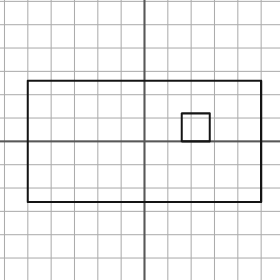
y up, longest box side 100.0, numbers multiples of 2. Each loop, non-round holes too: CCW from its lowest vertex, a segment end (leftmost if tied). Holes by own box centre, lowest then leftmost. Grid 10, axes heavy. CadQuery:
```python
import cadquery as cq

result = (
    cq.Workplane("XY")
    .moveTo(-50.0, -26.0)
    .lineTo(50.0, -26.0)
    .lineTo(50.0, 26.0)
    .lineTo(-50.0, 26.0)
    .close()
    .moveTo(16.0, 0.0)
    .lineTo(28.0, 0.0)
    .lineTo(28.0, 12.0)
    .lineTo(16.0, 12.0)
    .close()
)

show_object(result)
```